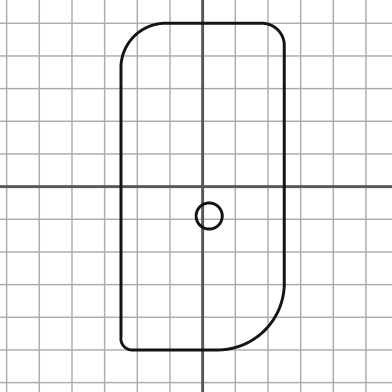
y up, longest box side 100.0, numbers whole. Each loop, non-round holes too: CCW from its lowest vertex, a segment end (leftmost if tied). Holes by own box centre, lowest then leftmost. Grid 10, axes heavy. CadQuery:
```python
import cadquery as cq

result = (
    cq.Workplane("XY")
    .moveTo(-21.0, -50.0)
    .lineTo(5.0, -50.0)
    .threePointArc((19.0, -44.0), (25.0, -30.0))
    .lineTo(25.0, 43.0)
    .threePointArc((23.0, 48.0), (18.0, 50.0))
    .lineTo(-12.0, 50.0)
    .threePointArc((-21.0, 46.0), (-25.0, 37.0))
    .lineTo(-25.0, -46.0)
    .threePointArc((-24.0, -49.0), (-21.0, -50.0))
    .close()
    .moveTo(2.0, -9.0)
    .circle(4.0)
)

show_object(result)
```